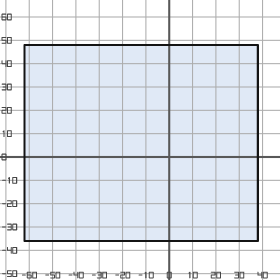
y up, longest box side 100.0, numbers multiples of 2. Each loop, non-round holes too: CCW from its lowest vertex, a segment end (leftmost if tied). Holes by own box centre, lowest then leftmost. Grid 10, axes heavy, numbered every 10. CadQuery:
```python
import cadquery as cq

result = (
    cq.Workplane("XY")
    .moveTo(-62.0, -36.0)
    .lineTo(38.0, -36.0)
    .lineTo(38.0, 48.0)
    .lineTo(-62.0, 48.0)
    .close()
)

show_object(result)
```